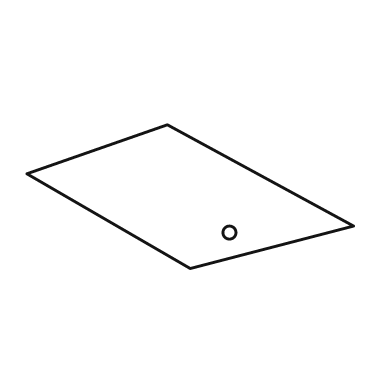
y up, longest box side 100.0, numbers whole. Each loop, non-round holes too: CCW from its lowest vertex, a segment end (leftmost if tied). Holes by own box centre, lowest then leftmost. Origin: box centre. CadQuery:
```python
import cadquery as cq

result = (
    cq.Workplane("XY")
    .moveTo(0.0, -22.0)
    .lineTo(50.0, -9.0)
    .lineTo(-7.0, 22.0)
    .lineTo(-50.0, 7.0)
    .close()
    .moveTo(12.0, -11.0)
    .circle(2.0)
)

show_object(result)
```